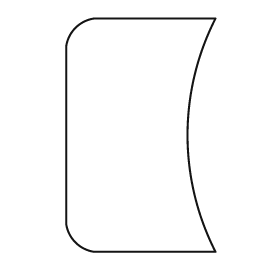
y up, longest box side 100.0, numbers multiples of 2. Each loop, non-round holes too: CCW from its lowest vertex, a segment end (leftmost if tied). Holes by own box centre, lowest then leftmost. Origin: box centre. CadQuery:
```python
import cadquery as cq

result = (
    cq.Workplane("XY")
    .moveTo(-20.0, -50.0)
    .lineTo(32.0, -50.0)
    .threePointArc((20.0, 0.0), (32.0, 50.0))
    .lineTo(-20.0, 50.0)
    .threePointArc((-28.0, 46.0), (-32.0, 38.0))
    .lineTo(-32.0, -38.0)
    .threePointArc((-28.0, -46.0), (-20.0, -50.0))
    .close()
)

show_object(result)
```